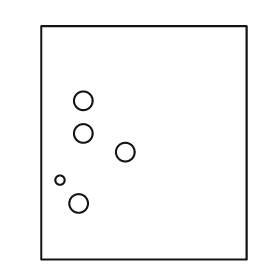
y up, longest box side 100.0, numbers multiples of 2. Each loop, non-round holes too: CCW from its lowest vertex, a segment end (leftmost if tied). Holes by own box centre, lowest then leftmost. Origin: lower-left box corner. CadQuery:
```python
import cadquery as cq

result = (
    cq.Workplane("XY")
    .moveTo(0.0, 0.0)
    .lineTo(88.0, 0.0)
    .lineTo(88.0, 100.0)
    .lineTo(0.0, 100.0)
    .close()
    .moveTo(16.0, 24.0)
    .circle(4.0)
    .moveTo(8.0, 34.0)
    .circle(2.0)
    .moveTo(36.0, 46.0)
    .circle(4.0)
    .moveTo(18.0, 54.0)
    .circle(4.0)
    .moveTo(18.0, 68.0)
    .circle(4.0)
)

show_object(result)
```